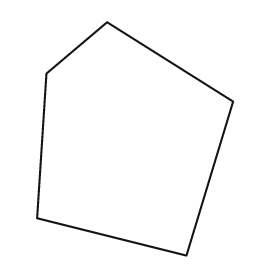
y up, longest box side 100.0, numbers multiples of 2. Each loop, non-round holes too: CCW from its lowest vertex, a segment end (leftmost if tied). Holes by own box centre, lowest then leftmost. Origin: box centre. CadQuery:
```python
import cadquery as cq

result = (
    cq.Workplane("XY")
    .moveTo(22.0, -50.0)
    .lineTo(42.0, 16.0)
    .lineTo(-12.0, 50.0)
    .lineTo(-38.0, 28.0)
    .lineTo(-42.0, -34.0)
    .close()
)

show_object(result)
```